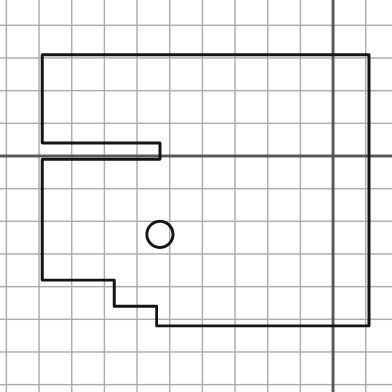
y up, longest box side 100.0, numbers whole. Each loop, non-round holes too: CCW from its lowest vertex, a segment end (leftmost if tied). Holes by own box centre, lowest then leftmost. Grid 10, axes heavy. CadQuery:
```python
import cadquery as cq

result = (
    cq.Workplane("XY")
    .moveTo(-54.0, -52.0)
    .lineTo(11.0, -52.0)
    .lineTo(11.0, 31.0)
    .lineTo(-89.0, 31.0)
    .lineTo(-89.0, 4.0)
    .lineTo(-53.0, 4.0)
    .lineTo(-53.0, -1.0)
    .lineTo(-89.0, -1.0)
    .lineTo(-89.0, -38.0)
    .lineTo(-67.0, -38.0)
    .lineTo(-67.0, -46.0)
    .lineTo(-54.0, -46.0)
    .close()
    .moveTo(-53.0, -24.0)
    .circle(4.0)
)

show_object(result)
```